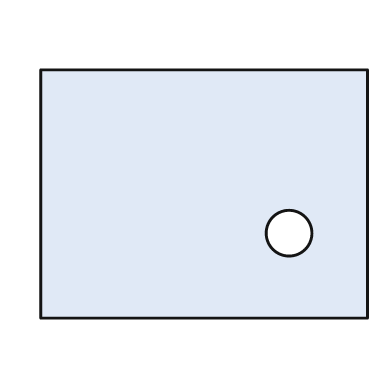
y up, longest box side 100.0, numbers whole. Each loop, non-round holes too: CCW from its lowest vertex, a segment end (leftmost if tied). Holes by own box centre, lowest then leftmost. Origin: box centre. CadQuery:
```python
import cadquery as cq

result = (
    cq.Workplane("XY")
    .moveTo(-50.0, -38.0)
    .lineTo(50.0, -38.0)
    .lineTo(50.0, 38.0)
    .lineTo(-50.0, 38.0)
    .close()
    .moveTo(26.0, -12.0)
    .circle(7.0)
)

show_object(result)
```